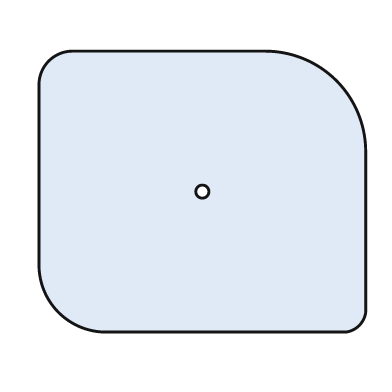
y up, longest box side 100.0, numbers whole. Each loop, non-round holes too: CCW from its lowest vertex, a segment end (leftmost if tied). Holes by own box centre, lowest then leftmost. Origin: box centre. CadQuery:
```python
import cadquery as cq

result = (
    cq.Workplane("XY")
    .moveTo(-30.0, -43.0)
    .lineTo(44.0, -43.0)
    .threePointArc((48.0, -41.0), (50.0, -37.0))
    .lineTo(50.0, 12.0)
    .threePointArc((41.0, 34.0), (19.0, 43.0))
    .lineTo(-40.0, 43.0)
    .threePointArc((-47.0, 40.0), (-50.0, 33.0))
    .lineTo(-50.0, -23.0)
    .threePointArc((-44.0, -37.0), (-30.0, -43.0))
    .close()
    .moveTo(0.0, 0.0)
    .circle(2.0)
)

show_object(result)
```